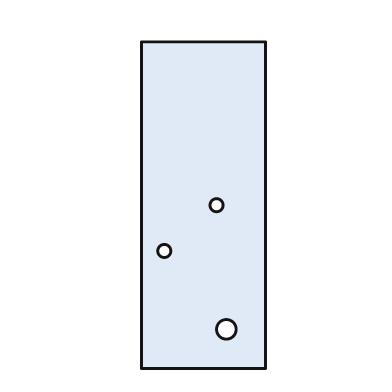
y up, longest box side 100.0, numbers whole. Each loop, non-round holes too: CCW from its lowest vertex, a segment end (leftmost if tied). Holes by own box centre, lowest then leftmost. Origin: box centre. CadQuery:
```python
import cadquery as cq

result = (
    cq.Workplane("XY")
    .moveTo(-19.0, -50.0)
    .lineTo(19.0, -50.0)
    .lineTo(19.0, 50.0)
    .lineTo(-19.0, 50.0)
    .close()
    .moveTo(7.0, -38.0)
    .circle(3.0)
    .moveTo(-12.0, -14.0)
    .circle(2.0)
    .moveTo(4.0, 0.0)
    .circle(2.0)
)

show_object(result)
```